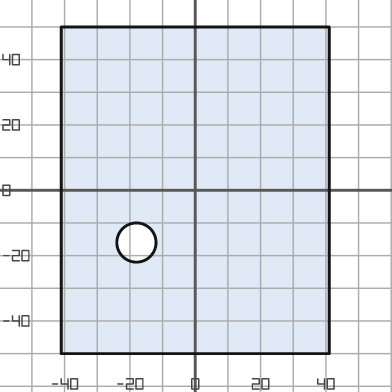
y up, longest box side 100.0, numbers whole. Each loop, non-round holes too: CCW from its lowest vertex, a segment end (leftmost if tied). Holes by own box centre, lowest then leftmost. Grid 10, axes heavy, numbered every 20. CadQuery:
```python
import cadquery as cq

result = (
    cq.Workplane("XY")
    .moveTo(-41.0, -50.0)
    .lineTo(41.0, -50.0)
    .lineTo(41.0, 50.0)
    .lineTo(-41.0, 50.0)
    .close()
    .moveTo(-18.0, -16.0)
    .circle(6.0)
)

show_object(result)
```